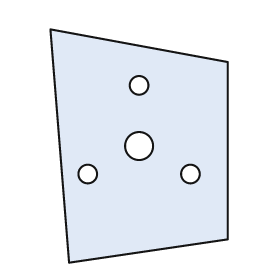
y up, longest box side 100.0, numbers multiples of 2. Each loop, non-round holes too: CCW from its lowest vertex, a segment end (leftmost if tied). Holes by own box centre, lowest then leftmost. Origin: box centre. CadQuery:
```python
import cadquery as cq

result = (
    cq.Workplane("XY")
    .moveTo(-30.0, -50.0)
    .lineTo(38.0, -40.0)
    .lineTo(38.0, 36.0)
    .lineTo(-38.0, 50.0)
    .close()
    .moveTo(-22.0, -12.0)
    .circle(4.0)
    .moveTo(22.0, -12.0)
    .circle(4.0)
    .moveTo(0.0, 0.0)
    .circle(6.0)
    .moveTo(0.0, 26.0)
    .circle(4.0)
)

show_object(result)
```